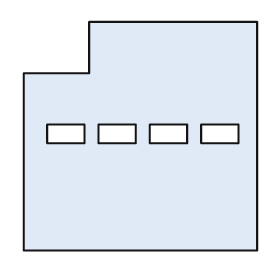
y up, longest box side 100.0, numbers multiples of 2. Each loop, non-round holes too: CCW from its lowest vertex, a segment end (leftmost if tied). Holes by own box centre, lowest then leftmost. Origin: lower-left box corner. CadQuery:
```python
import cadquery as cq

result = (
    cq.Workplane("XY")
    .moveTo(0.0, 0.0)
    .lineTo(100.0, 0.0)
    .lineTo(100.0, 98.0)
    .lineTo(28.0, 98.0)
    .lineTo(28.0, 76.0)
    .lineTo(0.0, 76.0)
    .close()
    .moveTo(10.0, 46.0)
    .lineTo(26.0, 46.0)
    .lineTo(26.0, 54.0)
    .lineTo(10.0, 54.0)
    .close()
    .moveTo(32.0, 46.0)
    .lineTo(48.0, 46.0)
    .lineTo(48.0, 54.0)
    .lineTo(32.0, 54.0)
    .close()
    .moveTo(54.0, 46.0)
    .lineTo(70.0, 46.0)
    .lineTo(70.0, 54.0)
    .lineTo(54.0, 54.0)
    .close()
    .moveTo(76.0, 46.0)
    .lineTo(92.0, 46.0)
    .lineTo(92.0, 54.0)
    .lineTo(76.0, 54.0)
    .close()
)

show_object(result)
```